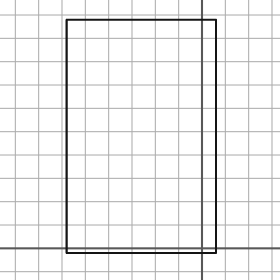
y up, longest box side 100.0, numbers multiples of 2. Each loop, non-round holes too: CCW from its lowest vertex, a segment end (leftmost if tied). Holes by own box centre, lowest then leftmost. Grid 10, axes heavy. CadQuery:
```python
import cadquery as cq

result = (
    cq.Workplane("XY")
    .moveTo(-58.0, -2.0)
    .lineTo(6.0, -2.0)
    .lineTo(6.0, 98.0)
    .lineTo(-58.0, 98.0)
    .close()
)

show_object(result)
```